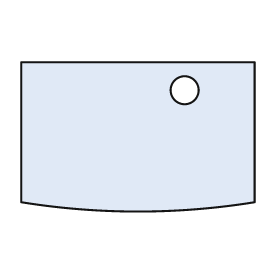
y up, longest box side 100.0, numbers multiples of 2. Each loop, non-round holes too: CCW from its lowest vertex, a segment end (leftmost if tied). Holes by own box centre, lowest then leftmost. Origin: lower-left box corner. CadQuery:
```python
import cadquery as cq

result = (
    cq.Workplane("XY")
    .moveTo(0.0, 4.0)
    .threePointArc((50.0, 0.0), (100.0, 4.0))
    .lineTo(100.0, 64.0)
    .lineTo(0.0, 64.0)
    .close()
    .moveTo(70.0, 52.0)
    .circle(6.0)
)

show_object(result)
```